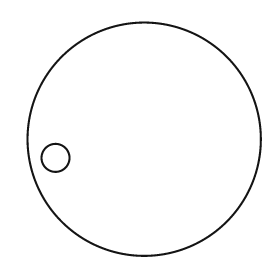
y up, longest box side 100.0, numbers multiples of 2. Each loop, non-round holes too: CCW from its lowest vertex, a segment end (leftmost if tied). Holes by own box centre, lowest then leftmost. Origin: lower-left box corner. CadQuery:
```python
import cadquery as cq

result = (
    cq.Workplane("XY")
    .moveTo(50.0, 50.0)
    .circle(50.0)
    .moveTo(12.0, 42.0)
    .circle(6.0)
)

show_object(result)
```